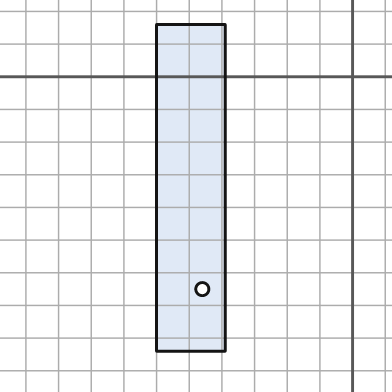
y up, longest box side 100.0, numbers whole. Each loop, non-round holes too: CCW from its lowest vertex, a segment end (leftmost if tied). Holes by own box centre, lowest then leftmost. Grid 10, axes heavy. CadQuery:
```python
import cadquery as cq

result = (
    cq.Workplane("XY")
    .moveTo(-60.0, -84.0)
    .lineTo(-39.0, -84.0)
    .lineTo(-39.0, 16.0)
    .lineTo(-60.0, 16.0)
    .close()
    .moveTo(-46.0, -65.0)
    .circle(2.0)
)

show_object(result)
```